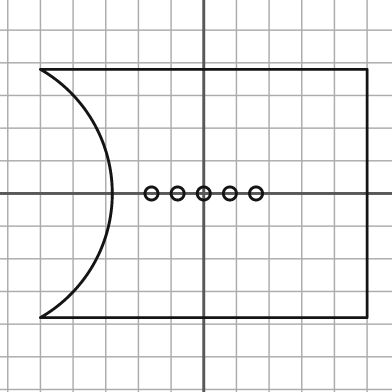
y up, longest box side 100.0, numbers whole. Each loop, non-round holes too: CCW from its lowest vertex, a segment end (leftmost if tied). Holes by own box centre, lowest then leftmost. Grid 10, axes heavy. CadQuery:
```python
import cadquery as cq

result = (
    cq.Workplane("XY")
    .moveTo(-50.0, -38.0)
    .lineTo(50.0, -38.0)
    .lineTo(50.0, 38.0)
    .lineTo(-50.0, 38.0)
    .threePointArc((-28.0, 0.0), (-50.0, -38.0))
    .close()
    .moveTo(-16.0, 0.0)
    .circle(2.0)
    .moveTo(-8.0, 0.0)
    .circle(2.0)
    .moveTo(0.0, 0.0)
    .circle(2.0)
    .moveTo(8.0, 0.0)
    .circle(2.0)
    .moveTo(16.0, 0.0)
    .circle(2.0)
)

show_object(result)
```